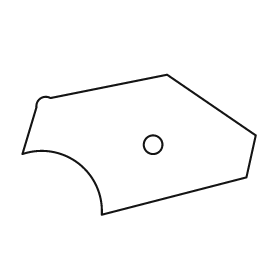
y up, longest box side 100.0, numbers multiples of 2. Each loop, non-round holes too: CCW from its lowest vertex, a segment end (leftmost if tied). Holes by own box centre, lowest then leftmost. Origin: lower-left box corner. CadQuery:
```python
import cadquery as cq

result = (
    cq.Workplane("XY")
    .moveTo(34.0, 0.0)
    .lineTo(96.0, 16.0)
    .lineTo(100.0, 34.0)
    .lineTo(62.0, 60.0)
    .lineTo(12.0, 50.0)
    .threePointArc((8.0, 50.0), (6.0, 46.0))
    .lineTo(0.0, 26.0)
    .threePointArc((24.0, 22.0), (34.0, 0.0))
    .close()
    .moveTo(56.0, 30.0)
    .circle(4.0)
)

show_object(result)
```